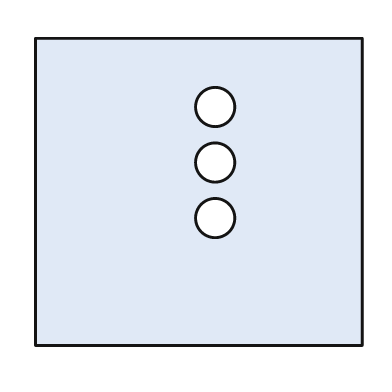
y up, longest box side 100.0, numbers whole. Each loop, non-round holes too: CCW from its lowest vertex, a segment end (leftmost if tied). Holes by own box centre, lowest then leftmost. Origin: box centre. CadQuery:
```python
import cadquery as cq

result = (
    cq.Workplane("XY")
    .moveTo(-50.0, -47.0)
    .lineTo(50.0, -47.0)
    .lineTo(50.0, 47.0)
    .lineTo(-50.0, 47.0)
    .close()
    .moveTo(5.0, -8.0)
    .circle(6.0)
    .moveTo(5.0, 9.0)
    .circle(6.0)
    .moveTo(5.0, 26.0)
    .circle(6.0)
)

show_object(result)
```